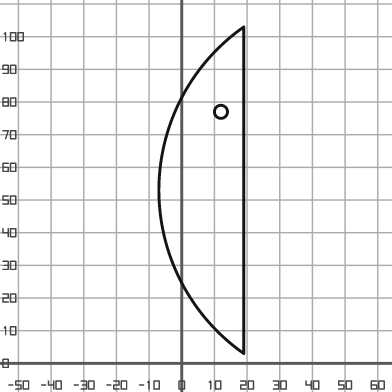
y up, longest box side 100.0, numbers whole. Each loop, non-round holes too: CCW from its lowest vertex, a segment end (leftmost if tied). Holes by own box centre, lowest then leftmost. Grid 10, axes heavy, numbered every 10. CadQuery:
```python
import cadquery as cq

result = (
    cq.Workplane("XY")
    .moveTo(19.0, 3.0)
    .lineTo(19.0, 103.0)
    .threePointArc((-7.0, 53.0), (19.0, 3.0))
    .close()
    .moveTo(12.0, 77.0)
    .circle(2.0)
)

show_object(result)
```